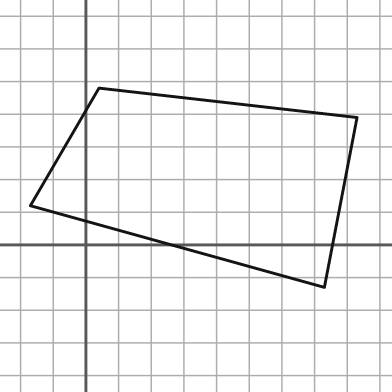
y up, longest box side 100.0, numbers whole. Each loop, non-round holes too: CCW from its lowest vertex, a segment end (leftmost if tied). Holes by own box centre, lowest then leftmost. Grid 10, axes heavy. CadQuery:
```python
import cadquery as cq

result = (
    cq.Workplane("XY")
    .moveTo(73.0, -13.0)
    .lineTo(83.0, 39.0)
    .lineTo(4.0, 48.0)
    .lineTo(-17.0, 12.0)
    .close()
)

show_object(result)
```